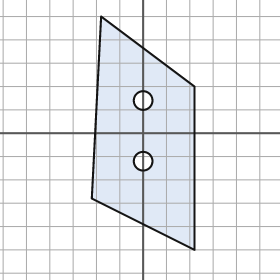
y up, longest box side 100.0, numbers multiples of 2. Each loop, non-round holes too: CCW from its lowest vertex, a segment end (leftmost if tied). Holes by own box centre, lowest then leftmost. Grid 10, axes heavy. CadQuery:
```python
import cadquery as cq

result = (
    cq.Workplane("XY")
    .moveTo(22.0, -50.0)
    .lineTo(22.0, 20.0)
    .lineTo(-18.0, 50.0)
    .lineTo(-22.0, -28.0)
    .close()
    .moveTo(0.0, -12.0)
    .circle(4.0)
    .moveTo(0.0, 14.0)
    .circle(4.0)
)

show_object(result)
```